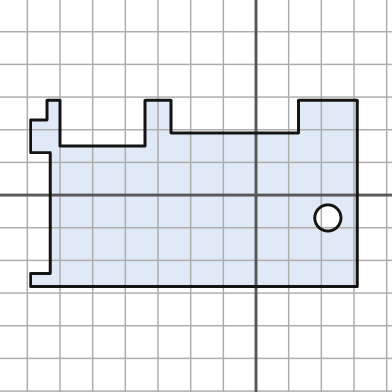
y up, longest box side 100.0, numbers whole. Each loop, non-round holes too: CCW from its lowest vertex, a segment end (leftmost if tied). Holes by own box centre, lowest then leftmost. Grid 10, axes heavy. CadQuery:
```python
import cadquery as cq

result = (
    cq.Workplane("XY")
    .moveTo(-69.0, -28.0)
    .lineTo(31.0, -28.0)
    .lineTo(31.0, 29.0)
    .lineTo(13.0, 29.0)
    .lineTo(13.0, 19.0)
    .lineTo(-26.0, 19.0)
    .lineTo(-26.0, 29.0)
    .lineTo(-34.0, 29.0)
    .lineTo(-34.0, 15.0)
    .lineTo(-60.0, 15.0)
    .lineTo(-60.0, 29.0)
    .lineTo(-64.0, 29.0)
    .lineTo(-64.0, 23.0)
    .lineTo(-69.0, 23.0)
    .lineTo(-69.0, 13.0)
    .lineTo(-63.0, 13.0)
    .lineTo(-63.0, -24.0)
    .lineTo(-69.0, -24.0)
    .close()
    .moveTo(22.0, -7.0)
    .circle(4.0)
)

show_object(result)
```